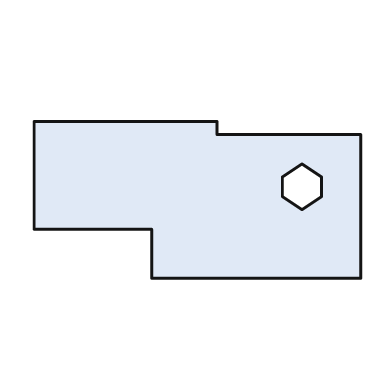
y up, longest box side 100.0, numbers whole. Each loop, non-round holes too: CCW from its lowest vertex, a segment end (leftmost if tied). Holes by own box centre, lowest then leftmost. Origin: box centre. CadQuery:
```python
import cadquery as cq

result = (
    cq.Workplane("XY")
    .moveTo(-14.0, -24.0)
    .lineTo(50.0, -24.0)
    .lineTo(50.0, 20.0)
    .lineTo(6.0, 20.0)
    .lineTo(6.0, 24.0)
    .lineTo(-50.0, 24.0)
    .lineTo(-50.0, -9.0)
    .lineTo(-14.0, -9.0)
    .close()
    .moveTo(32.0, -3.0)
    .lineTo(38.0, 1.0)
    .lineTo(38.0, 7.0)
    .lineTo(32.0, 11.0)
    .lineTo(26.0, 7.0)
    .lineTo(26.0, 1.0)
    .close()
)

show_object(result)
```